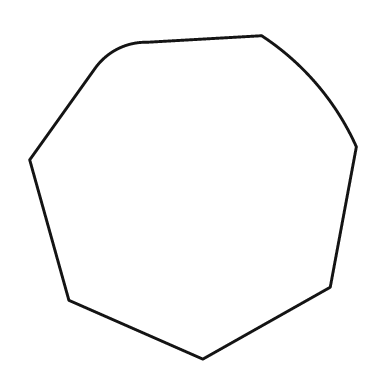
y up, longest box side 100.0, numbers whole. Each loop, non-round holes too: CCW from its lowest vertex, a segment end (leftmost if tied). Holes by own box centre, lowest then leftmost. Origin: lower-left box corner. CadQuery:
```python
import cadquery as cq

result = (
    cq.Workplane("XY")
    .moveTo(53.0, 0.0)
    .lineTo(92.0, 22.0)
    .lineTo(100.0, 65.0)
    .threePointArc((88.0, 84.0), (71.0, 99.0))
    .lineTo(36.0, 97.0)
    .threePointArc((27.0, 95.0), (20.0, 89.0))
    .lineTo(0.0, 61.0)
    .lineTo(12.0, 18.0)
    .close()
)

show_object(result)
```